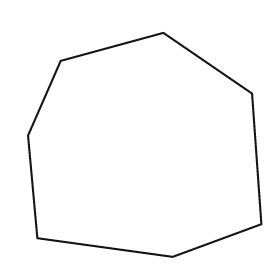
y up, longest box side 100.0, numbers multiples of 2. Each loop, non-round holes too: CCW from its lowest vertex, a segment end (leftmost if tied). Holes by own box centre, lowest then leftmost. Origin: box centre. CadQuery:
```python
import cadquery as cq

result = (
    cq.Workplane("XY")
    .moveTo(12.0, -48.0)
    .lineTo(50.0, -34.0)
    .lineTo(46.0, 22.0)
    .lineTo(8.0, 48.0)
    .lineTo(-36.0, 36.0)
    .lineTo(-50.0, 4.0)
    .lineTo(-46.0, -40.0)
    .close()
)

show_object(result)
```